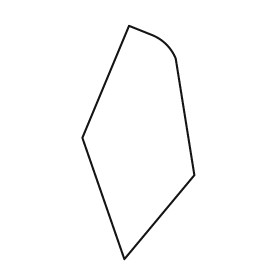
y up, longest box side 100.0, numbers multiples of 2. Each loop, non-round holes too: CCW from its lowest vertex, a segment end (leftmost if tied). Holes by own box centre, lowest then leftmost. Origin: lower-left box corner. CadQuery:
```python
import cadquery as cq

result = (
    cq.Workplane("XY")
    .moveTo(18.0, 0.0)
    .lineTo(48.0, 36.0)
    .lineTo(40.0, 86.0)
    .threePointArc((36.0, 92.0), (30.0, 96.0))
    .lineTo(20.0, 100.0)
    .lineTo(0.0, 52.0)
    .close()
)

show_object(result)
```